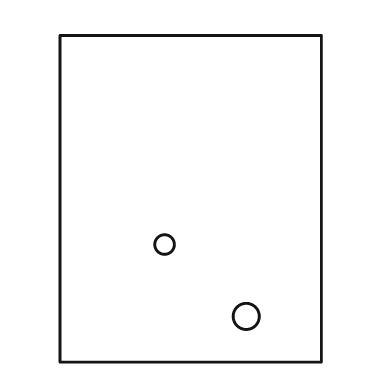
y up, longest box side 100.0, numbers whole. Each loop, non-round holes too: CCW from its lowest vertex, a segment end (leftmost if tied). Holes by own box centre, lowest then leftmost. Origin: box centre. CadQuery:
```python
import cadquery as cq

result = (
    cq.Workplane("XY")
    .moveTo(-40.0, -50.0)
    .lineTo(40.0, -50.0)
    .lineTo(40.0, 50.0)
    .lineTo(-40.0, 50.0)
    .close()
    .moveTo(17.0, -36.0)
    .circle(4.0)
    .moveTo(-8.0, -14.0)
    .circle(3.0)
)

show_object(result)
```